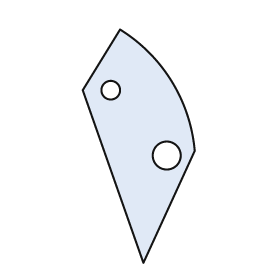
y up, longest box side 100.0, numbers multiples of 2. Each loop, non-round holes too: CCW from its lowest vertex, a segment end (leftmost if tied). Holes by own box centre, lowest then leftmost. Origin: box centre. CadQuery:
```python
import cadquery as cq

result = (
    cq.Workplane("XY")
    .moveTo(2.0, -50.0)
    .lineTo(24.0, -2.0)
    .threePointArc((14.0, 28.0), (-8.0, 50.0))
    .lineTo(-24.0, 24.0)
    .close()
    .moveTo(12.0, -4.0)
    .circle(6.0)
    .moveTo(-12.0, 24.0)
    .circle(4.0)
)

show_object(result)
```